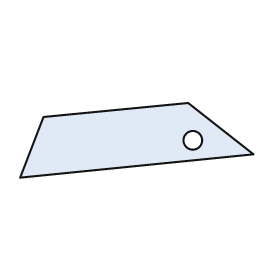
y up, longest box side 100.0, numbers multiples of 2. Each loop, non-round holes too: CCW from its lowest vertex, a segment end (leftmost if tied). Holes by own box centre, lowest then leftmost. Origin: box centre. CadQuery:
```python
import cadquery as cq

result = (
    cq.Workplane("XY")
    .moveTo(-50.0, -16.0)
    .lineTo(50.0, -6.0)
    .lineTo(22.0, 16.0)
    .lineTo(-40.0, 10.0)
    .close()
    .moveTo(24.0, 0.0)
    .circle(4.0)
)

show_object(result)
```